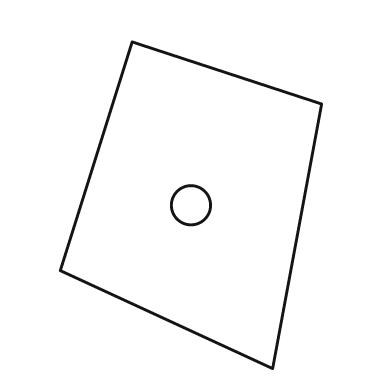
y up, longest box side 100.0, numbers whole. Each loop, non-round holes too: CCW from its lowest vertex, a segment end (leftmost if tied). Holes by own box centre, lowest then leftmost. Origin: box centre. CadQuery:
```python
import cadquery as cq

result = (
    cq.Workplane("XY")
    .moveTo(25.0, -50.0)
    .lineTo(40.0, 31.0)
    .lineTo(-18.0, 50.0)
    .lineTo(-40.0, -20.0)
    .close()
    .moveTo(0.0, 0.0)
    .circle(6.0)
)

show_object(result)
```